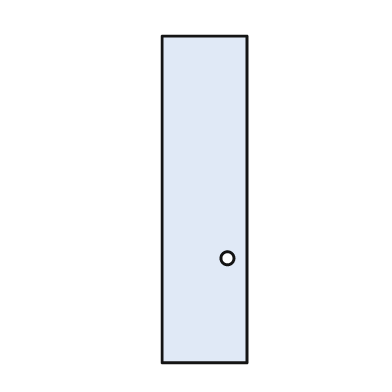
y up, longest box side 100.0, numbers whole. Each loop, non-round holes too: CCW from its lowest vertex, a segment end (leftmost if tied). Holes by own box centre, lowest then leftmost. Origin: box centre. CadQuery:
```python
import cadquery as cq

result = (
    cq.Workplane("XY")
    .moveTo(-13.0, -50.0)
    .lineTo(13.0, -50.0)
    .lineTo(13.0, 50.0)
    .lineTo(-13.0, 50.0)
    .close()
    .moveTo(7.0, -18.0)
    .circle(2.0)
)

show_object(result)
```